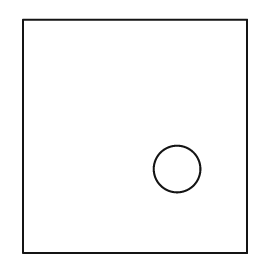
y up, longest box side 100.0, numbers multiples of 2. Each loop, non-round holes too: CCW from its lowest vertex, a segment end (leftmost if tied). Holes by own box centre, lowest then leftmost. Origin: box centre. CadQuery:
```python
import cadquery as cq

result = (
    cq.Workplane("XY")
    .moveTo(-48.0, -50.0)
    .lineTo(48.0, -50.0)
    .lineTo(48.0, 50.0)
    .lineTo(-48.0, 50.0)
    .close()
    .moveTo(18.0, -14.0)
    .circle(10.0)
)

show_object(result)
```